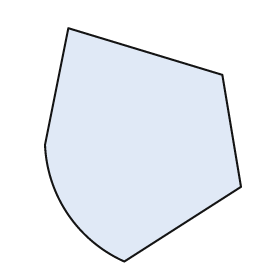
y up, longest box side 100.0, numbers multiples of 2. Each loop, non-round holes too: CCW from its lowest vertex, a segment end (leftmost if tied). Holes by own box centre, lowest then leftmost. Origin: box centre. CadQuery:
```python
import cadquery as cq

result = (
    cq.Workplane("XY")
    .moveTo(-8.0, -50.0)
    .lineTo(42.0, -18.0)
    .lineTo(34.0, 30.0)
    .lineTo(-32.0, 50.0)
    .lineTo(-42.0, 0.0)
    .threePointArc((-32.0, -30.0), (-8.0, -50.0))
    .close()
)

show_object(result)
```